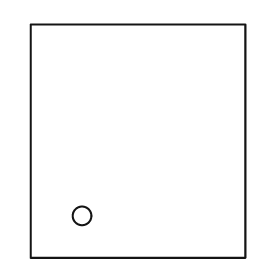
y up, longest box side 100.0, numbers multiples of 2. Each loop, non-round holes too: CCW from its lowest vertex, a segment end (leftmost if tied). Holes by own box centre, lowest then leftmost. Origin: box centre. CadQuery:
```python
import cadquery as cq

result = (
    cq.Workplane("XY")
    .moveTo(-46.0, -50.0)
    .lineTo(46.0, -50.0)
    .lineTo(46.0, 50.0)
    .lineTo(-46.0, 50.0)
    .close()
    .moveTo(-24.0, -32.0)
    .circle(4.0)
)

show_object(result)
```